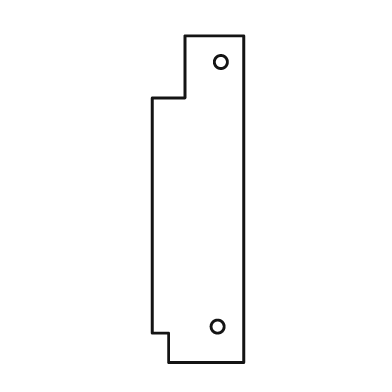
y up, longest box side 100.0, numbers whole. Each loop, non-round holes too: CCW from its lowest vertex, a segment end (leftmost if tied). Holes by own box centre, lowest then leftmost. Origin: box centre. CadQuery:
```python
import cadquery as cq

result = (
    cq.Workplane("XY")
    .moveTo(-9.0, -50.0)
    .lineTo(14.0, -50.0)
    .lineTo(14.0, 50.0)
    .lineTo(-4.0, 50.0)
    .lineTo(-4.0, 31.0)
    .lineTo(-14.0, 31.0)
    .lineTo(-14.0, -41.0)
    .lineTo(-9.0, -41.0)
    .close()
    .moveTo(6.0, -39.0)
    .circle(2.0)
    .moveTo(7.0, 42.0)
    .circle(2.0)
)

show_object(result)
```